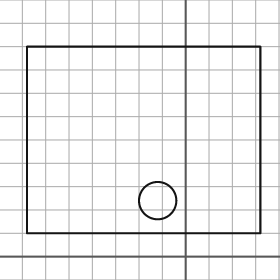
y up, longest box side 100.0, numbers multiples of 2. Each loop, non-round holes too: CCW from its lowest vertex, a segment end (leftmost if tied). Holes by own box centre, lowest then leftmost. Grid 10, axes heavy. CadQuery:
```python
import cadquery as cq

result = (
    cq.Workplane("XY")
    .moveTo(-68.0, 10.0)
    .lineTo(32.0, 10.0)
    .lineTo(32.0, 90.0)
    .lineTo(-68.0, 90.0)
    .close()
    .moveTo(-12.0, 24.0)
    .circle(8.0)
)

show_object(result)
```